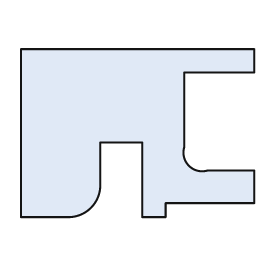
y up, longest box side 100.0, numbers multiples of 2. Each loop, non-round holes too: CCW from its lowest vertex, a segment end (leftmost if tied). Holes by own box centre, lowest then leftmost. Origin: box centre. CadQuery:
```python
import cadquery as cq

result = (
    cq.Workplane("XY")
    .moveTo(-50.0, -36.0)
    .lineTo(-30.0, -36.0)
    .threePointArc((-20.0, -32.0), (-16.0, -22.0))
    .lineTo(-16.0, -4.0)
    .lineTo(2.0, -4.0)
    .lineTo(2.0, -36.0)
    .lineTo(12.0, -36.0)
    .lineTo(12.0, -30.0)
    .lineTo(50.0, -30.0)
    .lineTo(50.0, -16.0)
    .lineTo(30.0, -16.0)
    .threePointArc((22.0, -14.0), (20.0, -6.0))
    .lineTo(20.0, 26.0)
    .lineTo(50.0, 26.0)
    .lineTo(50.0, 36.0)
    .lineTo(-50.0, 36.0)
    .close()
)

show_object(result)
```